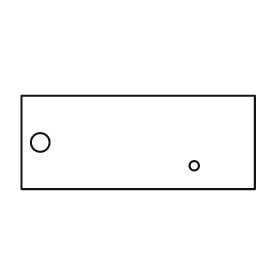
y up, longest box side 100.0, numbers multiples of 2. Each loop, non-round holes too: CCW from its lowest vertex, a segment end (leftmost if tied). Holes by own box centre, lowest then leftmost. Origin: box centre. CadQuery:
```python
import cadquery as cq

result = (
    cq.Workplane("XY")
    .moveTo(-50.0, -20.0)
    .lineTo(50.0, -20.0)
    .lineTo(50.0, 20.0)
    .lineTo(-50.0, 20.0)
    .close()
    .moveTo(24.0, -10.0)
    .circle(2.0)
    .moveTo(-42.0, 0.0)
    .circle(4.0)
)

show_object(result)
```